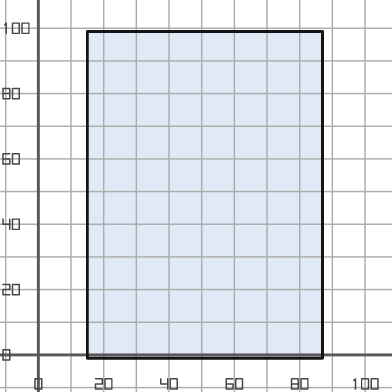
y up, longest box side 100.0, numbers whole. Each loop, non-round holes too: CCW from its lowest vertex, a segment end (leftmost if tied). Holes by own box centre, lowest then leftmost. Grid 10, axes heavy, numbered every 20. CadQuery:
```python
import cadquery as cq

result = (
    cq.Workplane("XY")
    .moveTo(15.0, -1.0)
    .lineTo(87.0, -1.0)
    .lineTo(87.0, 99.0)
    .lineTo(15.0, 99.0)
    .close()
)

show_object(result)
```